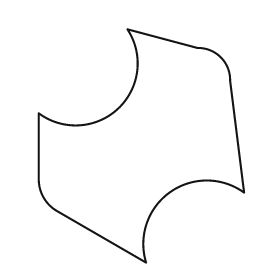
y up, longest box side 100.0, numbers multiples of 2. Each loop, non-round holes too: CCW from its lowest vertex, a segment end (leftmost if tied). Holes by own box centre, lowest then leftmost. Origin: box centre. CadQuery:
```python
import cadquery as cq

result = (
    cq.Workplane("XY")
    .moveTo(2.0, -50.0)
    .threePointArc((12.0, -20.0), (44.0, -20.0))
    .lineTo(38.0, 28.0)
    .threePointArc((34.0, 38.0), (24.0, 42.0))
    .lineTo(-6.0, 50.0)
    .threePointArc((-10.0, 16.0), (-44.0, 14.0))
    .lineTo(-44.0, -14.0)
    .threePointArc((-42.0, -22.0), (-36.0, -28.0))
    .close()
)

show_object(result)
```